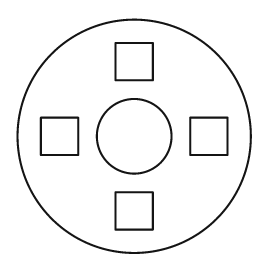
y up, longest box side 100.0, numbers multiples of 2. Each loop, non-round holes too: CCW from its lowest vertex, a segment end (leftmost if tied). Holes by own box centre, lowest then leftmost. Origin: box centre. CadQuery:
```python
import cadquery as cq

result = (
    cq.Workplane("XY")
    .moveTo(0.0, 0.0)
    .circle(50.0)
    .moveTo(-8.0, -40.0)
    .lineTo(8.0, -40.0)
    .lineTo(8.0, -24.0)
    .lineTo(-8.0, -24.0)
    .close()
    .moveTo(-40.0, -8.0)
    .lineTo(-24.0, -8.0)
    .lineTo(-24.0, 8.0)
    .lineTo(-40.0, 8.0)
    .close()
    .moveTo(0.0, 0.0)
    .circle(16.0)
    .moveTo(24.0, -8.0)
    .lineTo(40.0, -8.0)
    .lineTo(40.0, 8.0)
    .lineTo(24.0, 8.0)
    .close()
    .moveTo(-8.0, 24.0)
    .lineTo(8.0, 24.0)
    .lineTo(8.0, 40.0)
    .lineTo(-8.0, 40.0)
    .close()
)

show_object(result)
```